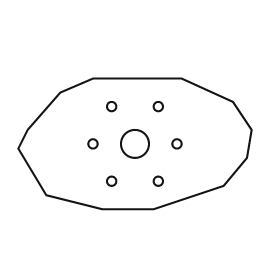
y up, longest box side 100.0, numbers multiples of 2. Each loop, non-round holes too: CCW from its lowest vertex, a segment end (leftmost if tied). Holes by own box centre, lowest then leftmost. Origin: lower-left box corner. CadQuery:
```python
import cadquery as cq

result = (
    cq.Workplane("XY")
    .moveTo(36.0, 0.0)
    .lineTo(58.0, 0.0)
    .lineTo(88.0, 10.0)
    .lineTo(98.0, 22.0)
    .lineTo(100.0, 34.0)
    .lineTo(92.0, 46.0)
    .lineTo(70.0, 56.0)
    .lineTo(32.0, 56.0)
    .lineTo(18.0, 50.0)
    .lineTo(4.0, 34.0)
    .lineTo(0.0, 26.0)
    .lineTo(12.0, 6.0)
    .close()
    .moveTo(40.0, 12.0)
    .circle(2.0)
    .moveTo(60.0, 12.0)
    .circle(2.0)
    .moveTo(32.0, 28.0)
    .circle(2.0)
    .moveTo(50.0, 28.0)
    .circle(6.0)
    .moveTo(68.0, 28.0)
    .circle(2.0)
    .moveTo(40.0, 44.0)
    .circle(2.0)
    .moveTo(60.0, 44.0)
    .circle(2.0)
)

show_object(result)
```